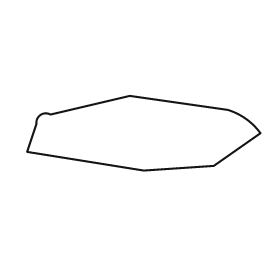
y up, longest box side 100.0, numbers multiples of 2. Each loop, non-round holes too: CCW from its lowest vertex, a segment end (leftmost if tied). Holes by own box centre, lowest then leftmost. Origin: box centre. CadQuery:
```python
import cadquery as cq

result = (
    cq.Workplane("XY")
    .moveTo(0.0, -16.0)
    .lineTo(30.0, -14.0)
    .lineTo(50.0, 0.0)
    .threePointArc((44.0, 6.0), (36.0, 10.0))
    .lineTo(-6.0, 16.0)
    .lineTo(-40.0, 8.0)
    .threePointArc((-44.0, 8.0), (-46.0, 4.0))
    .lineTo(-50.0, -8.0)
    .close()
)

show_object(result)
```